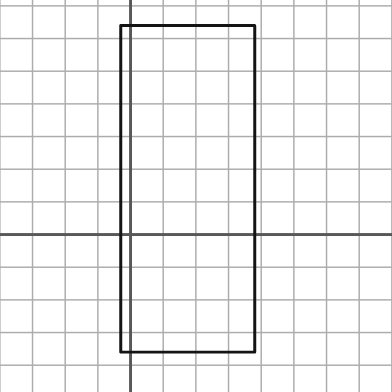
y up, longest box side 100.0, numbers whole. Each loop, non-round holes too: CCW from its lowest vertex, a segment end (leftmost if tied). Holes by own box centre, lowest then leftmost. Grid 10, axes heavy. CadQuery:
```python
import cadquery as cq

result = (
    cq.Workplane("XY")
    .moveTo(-3.0, -36.0)
    .lineTo(38.0, -36.0)
    .lineTo(38.0, 64.0)
    .lineTo(-3.0, 64.0)
    .close()
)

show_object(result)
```